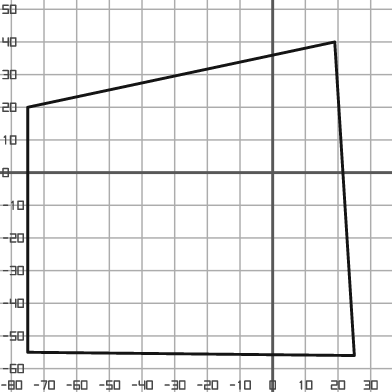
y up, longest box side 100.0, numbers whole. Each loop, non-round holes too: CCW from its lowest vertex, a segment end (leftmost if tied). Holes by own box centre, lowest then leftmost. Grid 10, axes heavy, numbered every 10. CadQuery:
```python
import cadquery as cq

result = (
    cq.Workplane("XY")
    .moveTo(25.0, -56.0)
    .lineTo(19.0, 40.0)
    .lineTo(-75.0, 20.0)
    .lineTo(-75.0, -55.0)
    .close()
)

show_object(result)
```